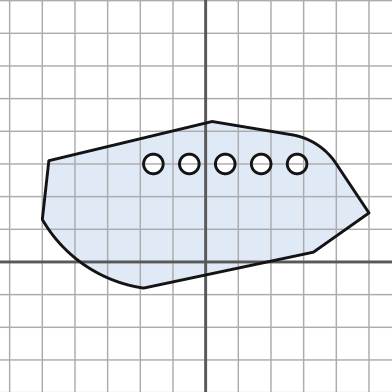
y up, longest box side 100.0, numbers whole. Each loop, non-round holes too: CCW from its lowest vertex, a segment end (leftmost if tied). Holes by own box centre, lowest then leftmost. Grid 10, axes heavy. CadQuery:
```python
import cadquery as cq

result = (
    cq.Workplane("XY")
    .moveTo(-19.0, -8.0)
    .lineTo(33.0, 3.0)
    .lineTo(50.0, 15.0)
    .lineTo(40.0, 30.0)
    .threePointArc((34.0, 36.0), (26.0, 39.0))
    .lineTo(2.0, 43.0)
    .lineTo(-48.0, 31.0)
    .lineTo(-50.0, 13.0)
    .threePointArc((-37.0, -1.0), (-19.0, -8.0))
    .close()
    .moveTo(-16.0, 30.0)
    .circle(3.0)
    .moveTo(-5.0, 30.0)
    .circle(3.0)
    .moveTo(6.0, 30.0)
    .circle(3.0)
    .moveTo(17.0, 30.0)
    .circle(3.0)
    .moveTo(28.0, 30.0)
    .circle(3.0)
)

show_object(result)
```